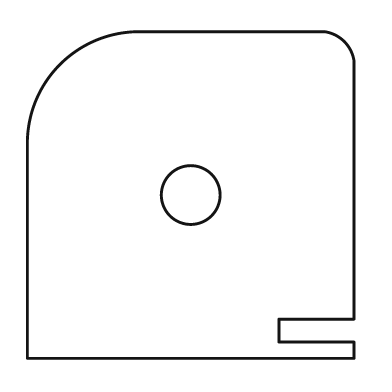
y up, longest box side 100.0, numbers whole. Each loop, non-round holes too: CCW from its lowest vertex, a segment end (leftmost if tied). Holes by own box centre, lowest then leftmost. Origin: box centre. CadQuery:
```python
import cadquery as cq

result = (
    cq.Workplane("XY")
    .moveTo(-50.0, -50.0)
    .lineTo(50.0, -50.0)
    .lineTo(50.0, -45.0)
    .lineTo(27.0, -45.0)
    .lineTo(27.0, -38.0)
    .lineTo(50.0, -38.0)
    .lineTo(50.0, 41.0)
    .threePointArc((47.0, 47.0), (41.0, 50.0))
    .lineTo(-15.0, 50.0)
    .threePointArc((-40.0, 40.0), (-50.0, 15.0))
    .close()
    .moveTo(0.0, 0.0)
    .circle(9.0)
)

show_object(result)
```